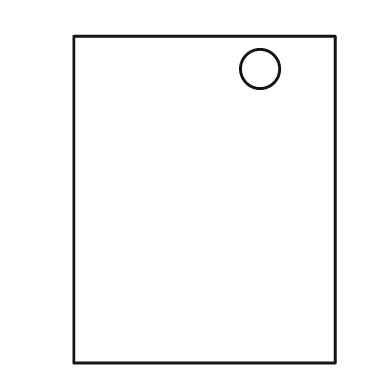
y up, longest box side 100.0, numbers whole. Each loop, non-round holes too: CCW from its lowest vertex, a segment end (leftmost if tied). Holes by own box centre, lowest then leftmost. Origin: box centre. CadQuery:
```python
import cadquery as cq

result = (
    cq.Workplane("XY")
    .moveTo(-40.0, -50.0)
    .lineTo(40.0, -50.0)
    .lineTo(40.0, 50.0)
    .lineTo(-40.0, 50.0)
    .close()
    .moveTo(17.0, 40.0)
    .circle(6.0)
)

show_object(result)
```